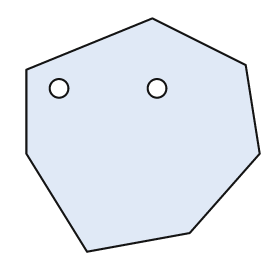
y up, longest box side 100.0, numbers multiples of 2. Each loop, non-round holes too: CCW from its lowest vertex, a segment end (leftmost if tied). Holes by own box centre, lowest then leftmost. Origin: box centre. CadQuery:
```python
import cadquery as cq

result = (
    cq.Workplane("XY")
    .moveTo(-24.0, -50.0)
    .lineTo(20.0, -42.0)
    .lineTo(50.0, -8.0)
    .lineTo(44.0, 30.0)
    .lineTo(4.0, 50.0)
    .lineTo(-50.0, 28.0)
    .lineTo(-50.0, -8.0)
    .close()
    .moveTo(-36.0, 20.0)
    .circle(4.0)
    .moveTo(6.0, 20.0)
    .circle(4.0)
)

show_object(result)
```